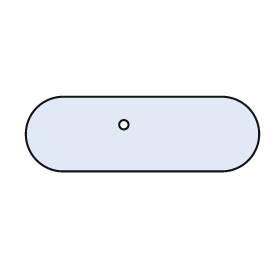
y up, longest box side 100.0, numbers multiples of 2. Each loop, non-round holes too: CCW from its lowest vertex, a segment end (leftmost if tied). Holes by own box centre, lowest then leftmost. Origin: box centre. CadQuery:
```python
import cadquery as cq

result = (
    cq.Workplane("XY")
    .moveTo(-34.0, -16.0)
    .lineTo(34.0, -16.0)
    .threePointArc((50.0, 0.0), (34.0, 16.0))
    .lineTo(-34.0, 16.0)
    .threePointArc((-50.0, 0.0), (-34.0, -16.0))
    .close()
    .moveTo(-8.0, 4.0)
    .circle(2.0)
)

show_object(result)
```